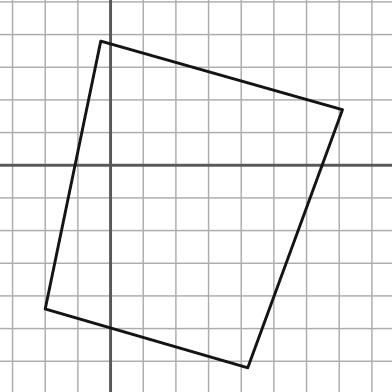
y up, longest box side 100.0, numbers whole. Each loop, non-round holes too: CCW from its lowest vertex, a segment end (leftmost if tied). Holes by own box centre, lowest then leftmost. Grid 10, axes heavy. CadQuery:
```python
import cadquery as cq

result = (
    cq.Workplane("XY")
    .moveTo(42.0, -62.0)
    .lineTo(71.0, 17.0)
    .lineTo(-3.0, 38.0)
    .lineTo(-20.0, -44.0)
    .close()
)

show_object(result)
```